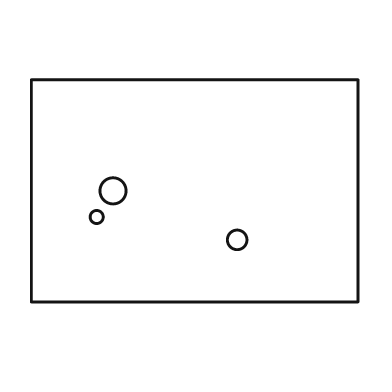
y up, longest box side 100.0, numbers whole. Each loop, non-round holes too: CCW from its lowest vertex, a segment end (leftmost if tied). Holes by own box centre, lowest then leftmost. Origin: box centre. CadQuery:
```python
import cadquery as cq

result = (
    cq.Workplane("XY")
    .moveTo(-50.0, -34.0)
    .lineTo(50.0, -34.0)
    .lineTo(50.0, 34.0)
    .lineTo(-50.0, 34.0)
    .close()
    .moveTo(13.0, -15.0)
    .circle(3.0)
    .moveTo(-30.0, -8.0)
    .circle(2.0)
    .moveTo(-25.0, 0.0)
    .circle(4.0)
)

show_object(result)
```